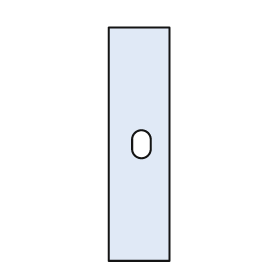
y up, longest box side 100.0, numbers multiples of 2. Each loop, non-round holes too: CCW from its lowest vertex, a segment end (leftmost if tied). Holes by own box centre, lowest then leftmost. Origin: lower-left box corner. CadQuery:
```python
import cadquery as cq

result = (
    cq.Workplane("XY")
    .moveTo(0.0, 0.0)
    .lineTo(26.0, 0.0)
    .lineTo(26.0, 100.0)
    .lineTo(0.0, 100.0)
    .close()
    .moveTo(10.0, 48.0)
    .threePointArc((14.0, 44.0), (18.0, 48.0))
    .lineTo(18.0, 52.0)
    .threePointArc((14.0, 56.0), (10.0, 52.0))
    .close()
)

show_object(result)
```